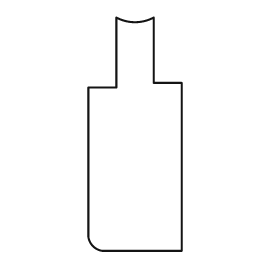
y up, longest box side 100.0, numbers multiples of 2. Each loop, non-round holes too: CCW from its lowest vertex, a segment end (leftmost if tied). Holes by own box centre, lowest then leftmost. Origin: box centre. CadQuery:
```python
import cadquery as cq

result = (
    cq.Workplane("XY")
    .moveTo(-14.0, -50.0)
    .lineTo(20.0, -50.0)
    .lineTo(20.0, 22.0)
    .lineTo(8.0, 22.0)
    .lineTo(8.0, 50.0)
    .threePointArc((0.0, 48.0), (-8.0, 50.0))
    .lineTo(-8.0, 20.0)
    .lineTo(-20.0, 20.0)
    .lineTo(-20.0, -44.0)
    .threePointArc((-18.0, -48.0), (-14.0, -50.0))
    .close()
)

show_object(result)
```